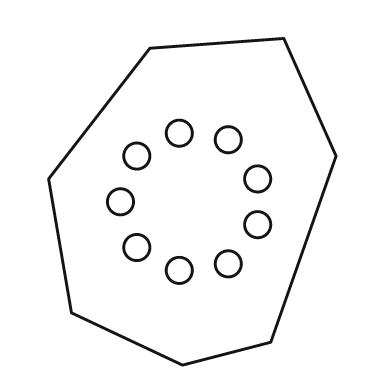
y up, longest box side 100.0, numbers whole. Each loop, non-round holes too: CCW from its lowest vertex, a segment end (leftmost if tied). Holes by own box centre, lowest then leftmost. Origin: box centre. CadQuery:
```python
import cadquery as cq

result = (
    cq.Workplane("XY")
    .moveTo(-3.0, -50.0)
    .lineTo(24.0, -43.0)
    .lineTo(44.0, 14.0)
    .lineTo(28.0, 50.0)
    .lineTo(-13.0, 47.0)
    .lineTo(-44.0, 7.0)
    .lineTo(-37.0, -34.0)
    .close()
    .moveTo(-4.0, -21.0)
    .circle(4.0)
    .moveTo(11.0, -19.0)
    .circle(4.0)
    .moveTo(-17.0, -14.0)
    .circle(4.0)
    .moveTo(20.0, -7.0)
    .circle(4.0)
    .moveTo(-22.0, 0.0)
    .circle(4.0)
    .moveTo(20.0, 7.0)
    .circle(4.0)
    .moveTo(-17.0, 14.0)
    .circle(4.0)
    .moveTo(11.0, 19.0)
    .circle(4.0)
    .moveTo(-4.0, 21.0)
    .circle(4.0)
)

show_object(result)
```